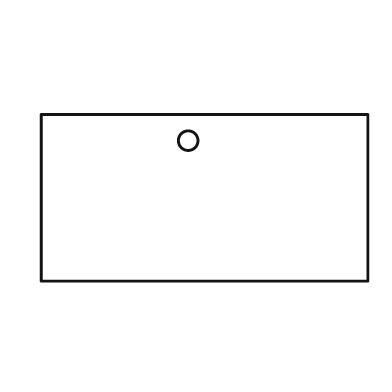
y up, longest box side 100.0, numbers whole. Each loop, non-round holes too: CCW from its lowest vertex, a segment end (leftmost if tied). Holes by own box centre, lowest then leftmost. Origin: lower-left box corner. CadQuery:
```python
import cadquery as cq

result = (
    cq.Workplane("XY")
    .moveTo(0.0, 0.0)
    .lineTo(100.0, 0.0)
    .lineTo(100.0, 51.0)
    .lineTo(0.0, 51.0)
    .close()
    .moveTo(45.0, 43.0)
    .circle(3.0)
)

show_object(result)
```